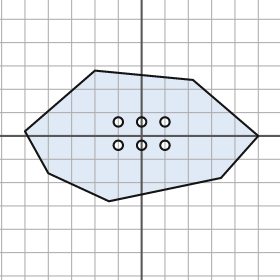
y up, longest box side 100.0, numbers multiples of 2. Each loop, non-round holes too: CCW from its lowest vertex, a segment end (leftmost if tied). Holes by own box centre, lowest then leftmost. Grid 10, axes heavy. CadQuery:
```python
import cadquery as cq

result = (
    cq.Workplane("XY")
    .moveTo(-14.0, -28.0)
    .lineTo(34.0, -18.0)
    .lineTo(50.0, 0.0)
    .lineTo(22.0, 24.0)
    .lineTo(-20.0, 28.0)
    .lineTo(-50.0, 2.0)
    .lineTo(-40.0, -16.0)
    .close()
    .moveTo(-10.0, -4.0)
    .circle(2.0)
    .moveTo(0.0, -4.0)
    .circle(2.0)
    .moveTo(10.0, -4.0)
    .circle(2.0)
    .moveTo(-10.0, 6.0)
    .circle(2.0)
    .moveTo(0.0, 6.0)
    .circle(2.0)
    .moveTo(10.0, 6.0)
    .circle(2.0)
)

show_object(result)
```